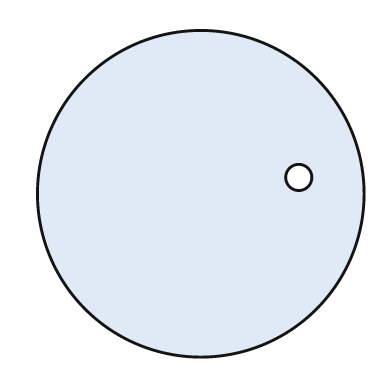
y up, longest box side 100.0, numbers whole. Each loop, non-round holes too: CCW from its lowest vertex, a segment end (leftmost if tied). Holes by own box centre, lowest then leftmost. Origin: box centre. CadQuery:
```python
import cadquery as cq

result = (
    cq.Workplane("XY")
    .moveTo(0.0, 0.0)
    .circle(50.0)
    .moveTo(30.0, 5.0)
    .circle(4.0)
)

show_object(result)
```